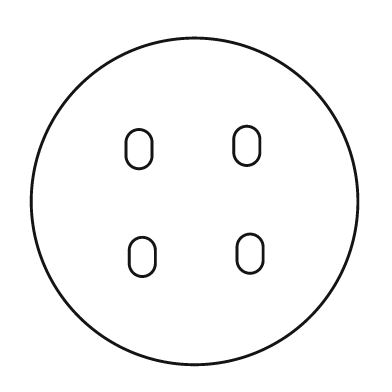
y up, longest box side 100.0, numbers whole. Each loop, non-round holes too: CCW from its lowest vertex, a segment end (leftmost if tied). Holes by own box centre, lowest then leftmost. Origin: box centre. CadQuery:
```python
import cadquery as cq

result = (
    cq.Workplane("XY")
    .moveTo(0.0, 0.0)
    .circle(50.0)
    .moveTo(-20.0, -19.0)
    .threePointArc((-16.0, -23.0), (-12.0, -19.0))
    .lineTo(-12.0, -15.0)
    .threePointArc((-16.0, -11.0), (-20.0, -15.0))
    .close()
    .moveTo(13.0, -18.0)
    .threePointArc((17.0, -22.0), (21.0, -18.0))
    .lineTo(21.0, -14.0)
    .threePointArc((17.0, -10.0), (13.0, -14.0))
    .close()
    .moveTo(-21.0, 14.0)
    .threePointArc((-17.0, 10.0), (-13.0, 14.0))
    .lineTo(-13.0, 18.0)
    .threePointArc((-17.0, 22.0), (-21.0, 18.0))
    .close()
    .moveTo(12.0, 15.0)
    .threePointArc((16.0, 11.0), (20.0, 15.0))
    .lineTo(20.0, 19.0)
    .threePointArc((16.0, 23.0), (12.0, 19.0))
    .close()
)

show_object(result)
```